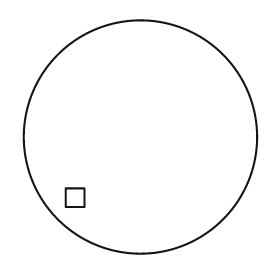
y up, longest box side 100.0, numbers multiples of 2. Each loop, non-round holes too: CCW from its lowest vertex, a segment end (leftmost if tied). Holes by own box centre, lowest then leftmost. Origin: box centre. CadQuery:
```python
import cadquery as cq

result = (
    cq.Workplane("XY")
    .moveTo(0.0, 0.0)
    .circle(50.0)
    .moveTo(-32.0, -30.0)
    .lineTo(-24.0, -30.0)
    .lineTo(-24.0, -22.0)
    .lineTo(-32.0, -22.0)
    .close()
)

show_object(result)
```